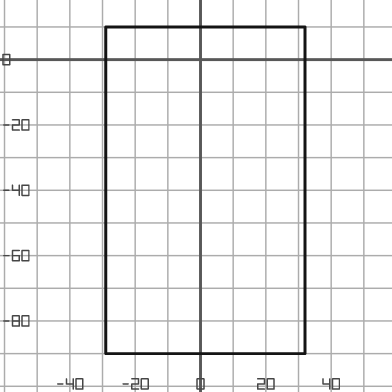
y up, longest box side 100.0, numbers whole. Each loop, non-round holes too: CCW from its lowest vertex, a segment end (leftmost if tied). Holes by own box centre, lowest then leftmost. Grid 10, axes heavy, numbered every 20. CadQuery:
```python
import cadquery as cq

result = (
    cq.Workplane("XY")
    .moveTo(-29.0, -90.0)
    .lineTo(32.0, -90.0)
    .lineTo(32.0, 10.0)
    .lineTo(-29.0, 10.0)
    .close()
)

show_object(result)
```